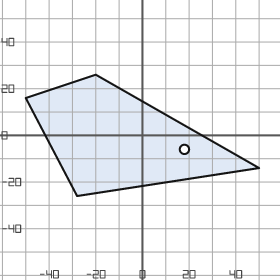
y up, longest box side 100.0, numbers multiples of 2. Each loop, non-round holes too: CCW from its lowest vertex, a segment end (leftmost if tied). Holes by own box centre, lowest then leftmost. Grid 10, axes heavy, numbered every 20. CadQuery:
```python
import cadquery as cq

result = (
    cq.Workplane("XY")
    .moveTo(-28.0, -26.0)
    .lineTo(50.0, -14.0)
    .lineTo(-20.0, 26.0)
    .lineTo(-50.0, 16.0)
    .close()
    .moveTo(18.0, -6.0)
    .circle(2.0)
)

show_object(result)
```